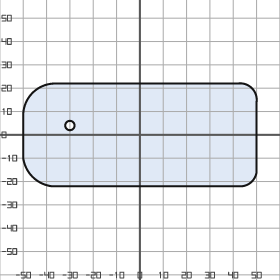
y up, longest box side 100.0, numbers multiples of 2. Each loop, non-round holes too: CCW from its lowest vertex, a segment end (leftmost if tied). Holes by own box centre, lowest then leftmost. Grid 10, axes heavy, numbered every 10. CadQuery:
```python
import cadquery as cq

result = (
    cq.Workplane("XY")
    .moveTo(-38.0, -22.0)
    .lineTo(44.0, -22.0)
    .threePointArc((48.0, -20.0), (50.0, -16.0))
    .lineTo(50.0, 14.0)
    .threePointArc((48.0, 20.0), (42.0, 22.0))
    .lineTo(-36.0, 22.0)
    .threePointArc((-46.0, 18.0), (-50.0, 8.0))
    .lineTo(-50.0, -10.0)
    .threePointArc((-46.0, -18.0), (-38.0, -22.0))
    .close()
    .moveTo(-30.0, 4.0)
    .circle(2.0)
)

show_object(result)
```